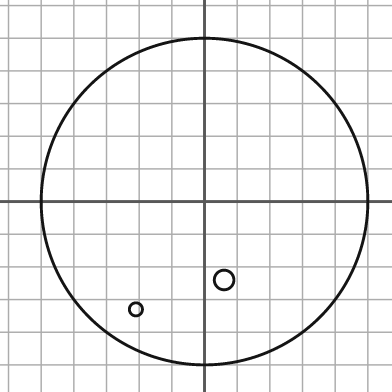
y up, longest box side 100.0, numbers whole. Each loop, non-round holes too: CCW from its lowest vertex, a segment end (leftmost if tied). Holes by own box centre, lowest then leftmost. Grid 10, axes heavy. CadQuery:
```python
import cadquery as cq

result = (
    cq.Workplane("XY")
    .moveTo(0.0, 0.0)
    .circle(50.0)
    .moveTo(-21.0, -33.0)
    .circle(2.0)
    .moveTo(6.0, -24.0)
    .circle(3.0)
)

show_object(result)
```